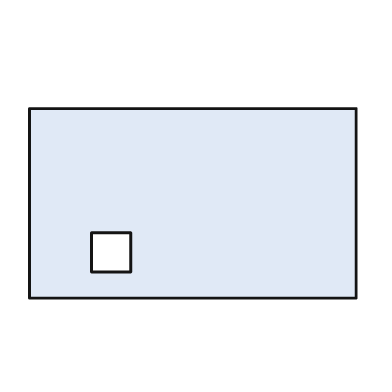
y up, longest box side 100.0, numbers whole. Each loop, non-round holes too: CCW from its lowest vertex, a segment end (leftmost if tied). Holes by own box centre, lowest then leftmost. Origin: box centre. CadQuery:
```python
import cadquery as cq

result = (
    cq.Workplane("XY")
    .moveTo(-50.0, -29.0)
    .lineTo(50.0, -29.0)
    .lineTo(50.0, 29.0)
    .lineTo(-50.0, 29.0)
    .close()
    .moveTo(-31.0, -21.0)
    .lineTo(-19.0, -21.0)
    .lineTo(-19.0, -9.0)
    .lineTo(-31.0, -9.0)
    .close()
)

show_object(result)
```